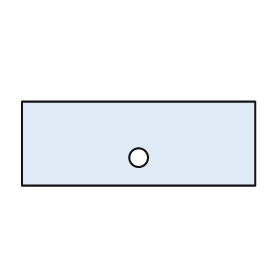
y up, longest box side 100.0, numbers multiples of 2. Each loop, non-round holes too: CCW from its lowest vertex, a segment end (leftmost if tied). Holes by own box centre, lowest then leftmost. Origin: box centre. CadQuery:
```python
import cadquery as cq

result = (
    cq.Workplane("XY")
    .moveTo(-50.0, -18.0)
    .lineTo(50.0, -18.0)
    .lineTo(50.0, 18.0)
    .lineTo(-50.0, 18.0)
    .close()
    .moveTo(0.0, -6.0)
    .circle(4.0)
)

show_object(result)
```